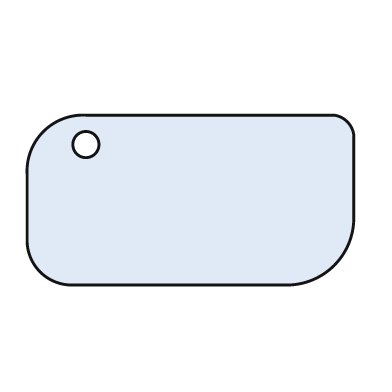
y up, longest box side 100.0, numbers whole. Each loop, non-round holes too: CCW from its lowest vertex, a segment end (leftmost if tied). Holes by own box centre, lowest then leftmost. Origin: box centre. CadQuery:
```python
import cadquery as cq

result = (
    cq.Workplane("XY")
    .moveTo(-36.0, -26.0)
    .lineTo(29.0, -26.0)
    .threePointArc((44.0, -20.0), (50.0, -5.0))
    .lineTo(50.0, 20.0)
    .threePointArc((48.0, 24.0), (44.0, 26.0))
    .lineTo(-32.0, 26.0)
    .threePointArc((-45.0, 21.0), (-50.0, 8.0))
    .lineTo(-50.0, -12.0)
    .threePointArc((-46.0, -22.0), (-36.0, -26.0))
    .close()
    .moveTo(-32.0, 17.0)
    .circle(4.0)
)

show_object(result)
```